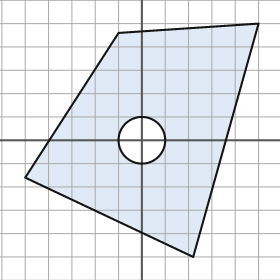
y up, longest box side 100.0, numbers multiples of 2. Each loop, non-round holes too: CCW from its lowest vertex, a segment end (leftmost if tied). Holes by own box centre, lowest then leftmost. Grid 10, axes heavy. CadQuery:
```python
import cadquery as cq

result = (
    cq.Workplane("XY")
    .moveTo(22.0, -50.0)
    .lineTo(50.0, 50.0)
    .lineTo(-10.0, 46.0)
    .lineTo(-50.0, -16.0)
    .close()
    .moveTo(0.0, 0.0)
    .circle(10.0)
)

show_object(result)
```